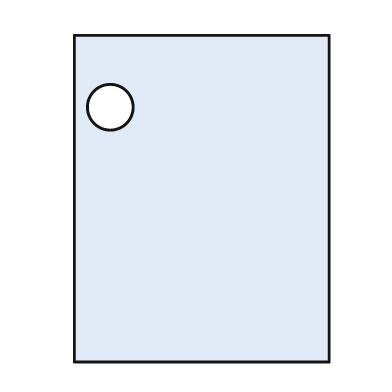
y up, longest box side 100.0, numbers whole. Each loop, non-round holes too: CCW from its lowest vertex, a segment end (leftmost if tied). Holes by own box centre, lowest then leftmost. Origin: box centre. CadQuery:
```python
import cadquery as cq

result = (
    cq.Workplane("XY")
    .moveTo(-39.0, -50.0)
    .lineTo(39.0, -50.0)
    .lineTo(39.0, 50.0)
    .lineTo(-39.0, 50.0)
    .close()
    .moveTo(-28.0, 28.0)
    .circle(7.0)
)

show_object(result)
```